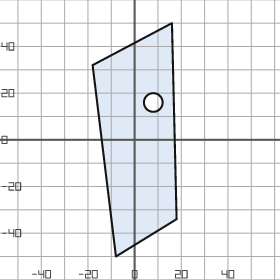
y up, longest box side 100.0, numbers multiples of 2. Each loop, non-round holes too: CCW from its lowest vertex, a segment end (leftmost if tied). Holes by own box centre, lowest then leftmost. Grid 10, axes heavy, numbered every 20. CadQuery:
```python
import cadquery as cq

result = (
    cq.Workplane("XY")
    .moveTo(-8.0, -50.0)
    .lineTo(18.0, -34.0)
    .lineTo(16.0, 50.0)
    .lineTo(-18.0, 32.0)
    .close()
    .moveTo(8.0, 16.0)
    .circle(4.0)
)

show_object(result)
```